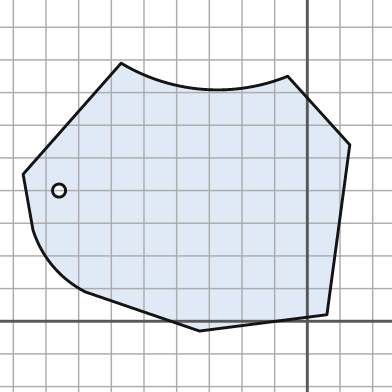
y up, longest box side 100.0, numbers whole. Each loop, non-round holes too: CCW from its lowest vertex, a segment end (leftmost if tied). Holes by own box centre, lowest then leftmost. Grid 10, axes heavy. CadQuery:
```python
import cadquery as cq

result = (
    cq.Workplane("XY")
    .moveTo(-33.0, -3.0)
    .lineTo(6.0, 2.0)
    .lineTo(13.0, 54.0)
    .lineTo(-6.0, 75.0)
    .threePointArc((-32.0, 71.0), (-57.0, 79.0))
    .lineTo(-87.0, 45.0)
    .lineTo(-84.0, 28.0)
    .threePointArc((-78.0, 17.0), (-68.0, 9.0))
    .close()
    .moveTo(-76.0, 40.0)
    .circle(2.0)
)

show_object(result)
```